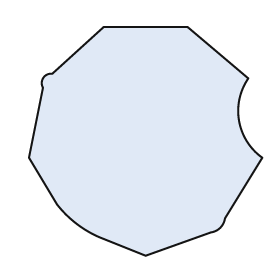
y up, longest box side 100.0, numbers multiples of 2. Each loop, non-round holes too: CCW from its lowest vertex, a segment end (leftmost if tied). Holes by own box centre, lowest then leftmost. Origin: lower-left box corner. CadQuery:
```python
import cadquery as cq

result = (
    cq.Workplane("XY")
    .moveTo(50.0, 0.0)
    .lineTo(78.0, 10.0)
    .threePointArc((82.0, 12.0), (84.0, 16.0))
    .lineTo(100.0, 42.0)
    .threePointArc((90.0, 58.0), (94.0, 76.0))
    .lineTo(68.0, 98.0)
    .lineTo(32.0, 98.0)
    .lineTo(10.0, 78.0)
    .threePointArc((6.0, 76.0), (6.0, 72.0))
    .lineTo(0.0, 42.0)
    .lineTo(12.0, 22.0)
    .threePointArc((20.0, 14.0), (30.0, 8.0))
    .close()
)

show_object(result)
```